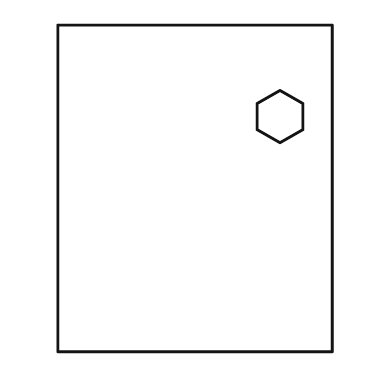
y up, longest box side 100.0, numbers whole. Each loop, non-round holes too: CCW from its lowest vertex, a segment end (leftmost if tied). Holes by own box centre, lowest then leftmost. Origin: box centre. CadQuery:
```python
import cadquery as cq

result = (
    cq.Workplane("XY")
    .moveTo(-42.0, -50.0)
    .lineTo(42.0, -50.0)
    .lineTo(42.0, 50.0)
    .lineTo(-42.0, 50.0)
    .close()
    .moveTo(26.0, 14.0)
    .lineTo(33.0, 18.0)
    .lineTo(33.0, 26.0)
    .lineTo(26.0, 30.0)
    .lineTo(19.0, 26.0)
    .lineTo(19.0, 18.0)
    .close()
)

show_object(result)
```